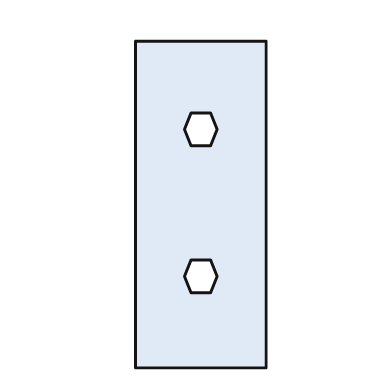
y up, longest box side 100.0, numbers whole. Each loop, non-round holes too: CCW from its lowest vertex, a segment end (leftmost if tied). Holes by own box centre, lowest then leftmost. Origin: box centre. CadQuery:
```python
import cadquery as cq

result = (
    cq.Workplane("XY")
    .moveTo(-20.0, -50.0)
    .lineTo(20.0, -50.0)
    .lineTo(20.0, 50.0)
    .lineTo(-20.0, 50.0)
    .close()
    .moveTo(-3.0, -27.0)
    .lineTo(3.0, -27.0)
    .lineTo(5.0, -22.0)
    .lineTo(3.0, -17.0)
    .lineTo(-3.0, -17.0)
    .lineTo(-5.0, -22.0)
    .close()
    .moveTo(-3.0, 18.0)
    .lineTo(3.0, 18.0)
    .lineTo(5.0, 23.0)
    .lineTo(3.0, 28.0)
    .lineTo(-3.0, 28.0)
    .lineTo(-5.0, 23.0)
    .close()
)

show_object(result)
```